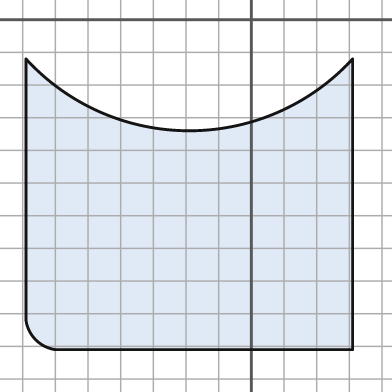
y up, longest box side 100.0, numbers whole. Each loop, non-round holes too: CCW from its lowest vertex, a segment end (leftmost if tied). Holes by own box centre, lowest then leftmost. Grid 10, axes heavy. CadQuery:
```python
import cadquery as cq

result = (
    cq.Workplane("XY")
    .moveTo(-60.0, -101.0)
    .lineTo(31.0, -101.0)
    .lineTo(31.0, -12.0)
    .threePointArc((-19.0, -34.0), (-69.0, -12.0))
    .lineTo(-69.0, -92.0)
    .threePointArc((-66.0, -98.0), (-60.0, -101.0))
    .close()
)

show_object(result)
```